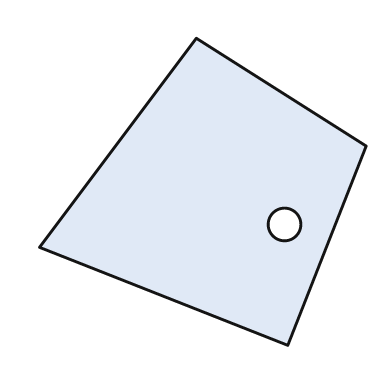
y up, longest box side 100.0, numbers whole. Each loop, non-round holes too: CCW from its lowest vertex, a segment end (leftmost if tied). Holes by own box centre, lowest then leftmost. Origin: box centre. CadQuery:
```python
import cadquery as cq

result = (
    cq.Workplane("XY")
    .moveTo(26.0, -47.0)
    .lineTo(50.0, 14.0)
    .lineTo(-2.0, 47.0)
    .lineTo(-50.0, -17.0)
    .close()
    .moveTo(25.0, -10.0)
    .circle(5.0)
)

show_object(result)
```